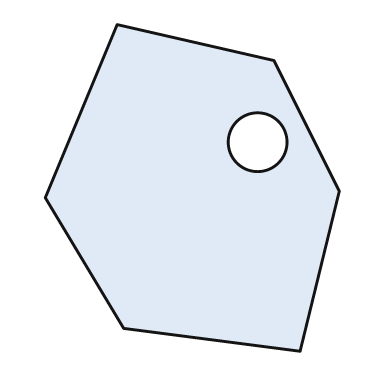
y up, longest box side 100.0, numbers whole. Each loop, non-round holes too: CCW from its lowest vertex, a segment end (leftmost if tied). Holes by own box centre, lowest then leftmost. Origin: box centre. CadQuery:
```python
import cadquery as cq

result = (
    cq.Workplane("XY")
    .moveTo(33.0, -50.0)
    .lineTo(45.0, -1.0)
    .lineTo(25.0, 39.0)
    .lineTo(-23.0, 50.0)
    .lineTo(-45.0, -3.0)
    .lineTo(-21.0, -43.0)
    .close()
    .moveTo(20.0, 14.0)
    .circle(9.0)
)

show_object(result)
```